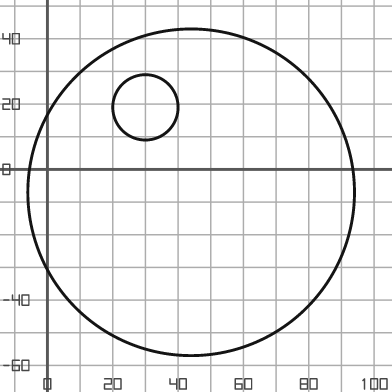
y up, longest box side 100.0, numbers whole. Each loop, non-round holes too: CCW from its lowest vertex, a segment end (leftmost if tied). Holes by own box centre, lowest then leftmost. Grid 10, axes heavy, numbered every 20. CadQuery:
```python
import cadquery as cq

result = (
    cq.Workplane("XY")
    .moveTo(44.0, -7.0)
    .circle(50.0)
    .moveTo(30.0, 19.0)
    .circle(10.0)
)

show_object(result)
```